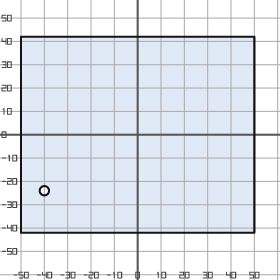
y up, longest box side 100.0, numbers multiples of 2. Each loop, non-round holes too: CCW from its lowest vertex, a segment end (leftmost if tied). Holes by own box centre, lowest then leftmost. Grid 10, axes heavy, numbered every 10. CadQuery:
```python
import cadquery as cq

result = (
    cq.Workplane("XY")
    .moveTo(-50.0, -42.0)
    .lineTo(50.0, -42.0)
    .lineTo(50.0, 42.0)
    .lineTo(-50.0, 42.0)
    .close()
    .moveTo(-40.0, -24.0)
    .circle(2.0)
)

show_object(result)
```